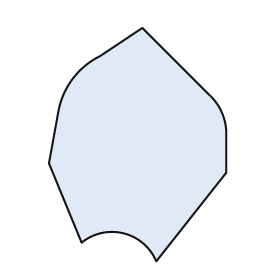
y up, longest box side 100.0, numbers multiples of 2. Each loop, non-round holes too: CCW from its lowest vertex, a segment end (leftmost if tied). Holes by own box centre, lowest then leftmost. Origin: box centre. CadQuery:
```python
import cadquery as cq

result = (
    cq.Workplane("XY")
    .moveTo(8.0, -50.0)
    .lineTo(38.0, -12.0)
    .lineTo(38.0, 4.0)
    .threePointArc((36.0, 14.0), (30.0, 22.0))
    .lineTo(2.0, 50.0)
    .lineTo(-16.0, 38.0)
    .threePointArc((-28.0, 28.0), (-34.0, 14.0))
    .lineTo(-38.0, -8.0)
    .lineTo(-24.0, -42.0)
    .threePointArc((-6.0, -38.0), (8.0, -50.0))
    .close()
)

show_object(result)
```